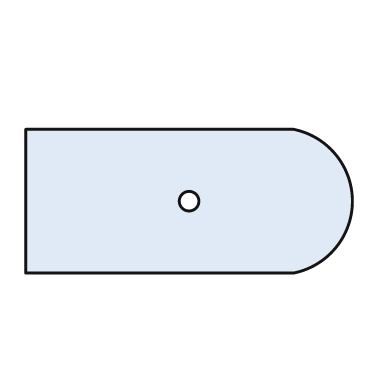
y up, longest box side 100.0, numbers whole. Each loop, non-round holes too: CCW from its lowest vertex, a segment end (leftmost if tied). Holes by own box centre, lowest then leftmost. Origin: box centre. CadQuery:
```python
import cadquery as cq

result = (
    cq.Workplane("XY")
    .moveTo(-50.0, -22.0)
    .lineTo(32.0, -22.0)
    .threePointArc((50.0, 0.0), (32.0, 22.0))
    .lineTo(-50.0, 22.0)
    .close()
    .moveTo(0.0, 0.0)
    .circle(3.0)
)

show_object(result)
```